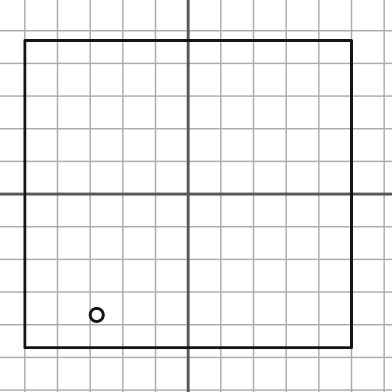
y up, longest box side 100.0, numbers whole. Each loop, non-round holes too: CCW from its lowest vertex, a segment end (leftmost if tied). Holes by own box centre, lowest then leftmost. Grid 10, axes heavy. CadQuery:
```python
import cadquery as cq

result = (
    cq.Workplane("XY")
    .moveTo(-50.0, -47.0)
    .lineTo(50.0, -47.0)
    .lineTo(50.0, 47.0)
    .lineTo(-50.0, 47.0)
    .close()
    .moveTo(-28.0, -37.0)
    .circle(2.0)
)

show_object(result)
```